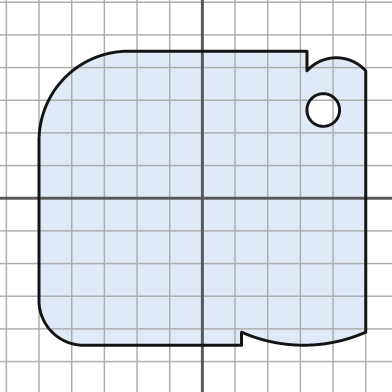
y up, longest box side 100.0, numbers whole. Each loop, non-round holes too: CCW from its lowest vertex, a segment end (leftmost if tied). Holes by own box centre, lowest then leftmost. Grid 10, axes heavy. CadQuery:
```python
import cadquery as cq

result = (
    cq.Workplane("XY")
    .moveTo(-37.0, -45.0)
    .lineTo(12.0, -45.0)
    .lineTo(12.0, -41.0)
    .threePointArc((31.0, -45.0), (50.0, -41.0))
    .lineTo(50.0, 39.0)
    .threePointArc((41.0, 43.0), (32.0, 39.0))
    .lineTo(32.0, 45.0)
    .lineTo(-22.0, 45.0)
    .threePointArc((-42.0, 37.0), (-50.0, 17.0))
    .lineTo(-50.0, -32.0)
    .threePointArc((-46.0, -41.0), (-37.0, -45.0))
    .close()
    .moveTo(37.0, 27.0)
    .circle(5.0)
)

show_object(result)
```